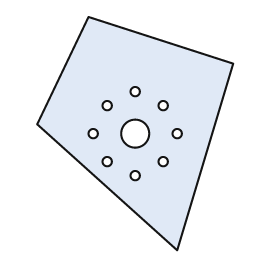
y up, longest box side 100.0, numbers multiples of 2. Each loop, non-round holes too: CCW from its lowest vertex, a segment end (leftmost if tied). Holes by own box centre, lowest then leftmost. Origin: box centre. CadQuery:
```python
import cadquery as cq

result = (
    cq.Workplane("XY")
    .moveTo(18.0, -50.0)
    .lineTo(42.0, 30.0)
    .lineTo(-20.0, 50.0)
    .lineTo(-42.0, 4.0)
    .close()
    .moveTo(0.0, -18.0)
    .circle(2.0)
    .moveTo(-12.0, -12.0)
    .circle(2.0)
    .moveTo(12.0, -12.0)
    .circle(2.0)
    .moveTo(-18.0, 0.0)
    .circle(2.0)
    .moveTo(0.0, 0.0)
    .circle(6.0)
    .moveTo(18.0, 0.0)
    .circle(2.0)
    .moveTo(-12.0, 12.0)
    .circle(2.0)
    .moveTo(12.0, 12.0)
    .circle(2.0)
    .moveTo(0.0, 18.0)
    .circle(2.0)
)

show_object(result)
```